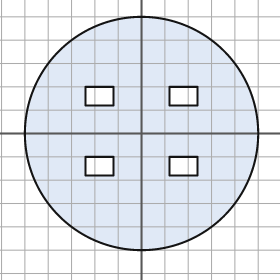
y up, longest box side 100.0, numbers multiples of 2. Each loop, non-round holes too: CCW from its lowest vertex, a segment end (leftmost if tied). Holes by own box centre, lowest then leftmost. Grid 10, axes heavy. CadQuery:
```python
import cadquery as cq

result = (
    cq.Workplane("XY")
    .moveTo(0.0, 0.0)
    .circle(50.0)
    .moveTo(-24.0, -18.0)
    .lineTo(-12.0, -18.0)
    .lineTo(-12.0, -10.0)
    .lineTo(-24.0, -10.0)
    .close()
    .moveTo(12.0, -18.0)
    .lineTo(24.0, -18.0)
    .lineTo(24.0, -10.0)
    .lineTo(12.0, -10.0)
    .close()
    .moveTo(-24.0, 12.0)
    .lineTo(-12.0, 12.0)
    .lineTo(-12.0, 20.0)
    .lineTo(-24.0, 20.0)
    .close()
    .moveTo(12.0, 12.0)
    .lineTo(24.0, 12.0)
    .lineTo(24.0, 20.0)
    .lineTo(12.0, 20.0)
    .close()
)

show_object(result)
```